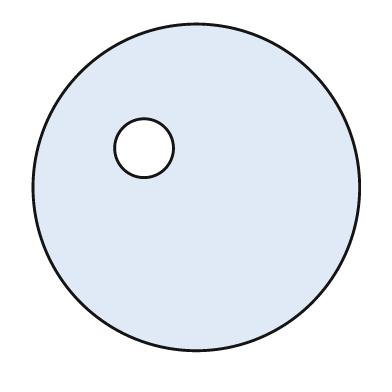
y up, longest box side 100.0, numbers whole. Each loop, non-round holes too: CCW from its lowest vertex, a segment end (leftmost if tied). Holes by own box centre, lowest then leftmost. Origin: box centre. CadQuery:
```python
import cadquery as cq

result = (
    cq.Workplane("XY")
    .moveTo(0.0, 0.0)
    .circle(50.0)
    .moveTo(-16.0, 12.0)
    .circle(9.0)
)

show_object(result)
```